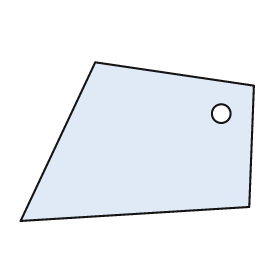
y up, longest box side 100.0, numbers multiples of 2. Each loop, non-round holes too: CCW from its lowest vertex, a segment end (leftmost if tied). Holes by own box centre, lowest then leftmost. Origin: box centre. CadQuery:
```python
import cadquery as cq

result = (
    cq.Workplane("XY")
    .moveTo(-50.0, -34.0)
    .lineTo(48.0, -28.0)
    .lineTo(50.0, 24.0)
    .lineTo(-18.0, 34.0)
    .close()
    .moveTo(36.0, 12.0)
    .circle(4.0)
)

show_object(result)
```